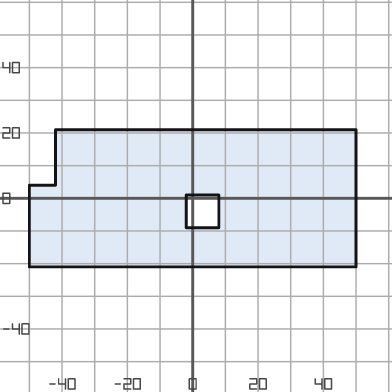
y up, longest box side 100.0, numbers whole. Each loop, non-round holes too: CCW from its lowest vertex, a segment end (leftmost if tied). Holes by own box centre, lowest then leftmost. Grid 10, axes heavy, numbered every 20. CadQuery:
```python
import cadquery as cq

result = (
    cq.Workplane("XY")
    .moveTo(-50.0, -21.0)
    .lineTo(50.0, -21.0)
    .lineTo(50.0, 21.0)
    .lineTo(-42.0, 21.0)
    .lineTo(-42.0, 4.0)
    .lineTo(-50.0, 4.0)
    .close()
    .moveTo(-2.0, -9.0)
    .lineTo(8.0, -9.0)
    .lineTo(8.0, 1.0)
    .lineTo(-2.0, 1.0)
    .close()
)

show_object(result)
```